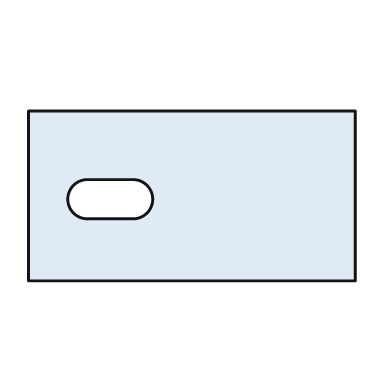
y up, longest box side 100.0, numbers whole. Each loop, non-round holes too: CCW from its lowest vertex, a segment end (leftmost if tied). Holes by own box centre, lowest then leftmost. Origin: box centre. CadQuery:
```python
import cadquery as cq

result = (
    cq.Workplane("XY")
    .moveTo(-50.0, -26.0)
    .lineTo(50.0, -26.0)
    .lineTo(50.0, 26.0)
    .lineTo(-50.0, 26.0)
    .close()
    .moveTo(-32.0, -7.0)
    .lineTo(-18.0, -7.0)
    .threePointArc((-12.0, -1.0), (-18.0, 5.0))
    .lineTo(-32.0, 5.0)
    .threePointArc((-38.0, -1.0), (-32.0, -7.0))
    .close()
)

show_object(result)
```